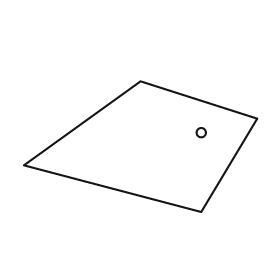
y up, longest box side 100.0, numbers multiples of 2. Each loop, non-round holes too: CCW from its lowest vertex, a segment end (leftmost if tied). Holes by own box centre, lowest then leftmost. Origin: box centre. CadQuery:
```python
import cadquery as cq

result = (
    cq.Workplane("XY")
    .moveTo(26.0, -28.0)
    .lineTo(50.0, 12.0)
    .lineTo(0.0, 28.0)
    .lineTo(-50.0, -8.0)
    .close()
    .moveTo(26.0, 6.0)
    .circle(2.0)
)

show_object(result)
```